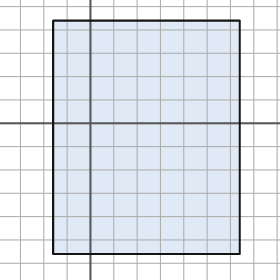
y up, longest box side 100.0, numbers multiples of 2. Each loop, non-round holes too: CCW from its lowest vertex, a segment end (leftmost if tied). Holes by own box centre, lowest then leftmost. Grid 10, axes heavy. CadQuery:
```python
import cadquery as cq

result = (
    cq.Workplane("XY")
    .moveTo(-16.0, -56.0)
    .lineTo(64.0, -56.0)
    .lineTo(64.0, 44.0)
    .lineTo(-16.0, 44.0)
    .close()
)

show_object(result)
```